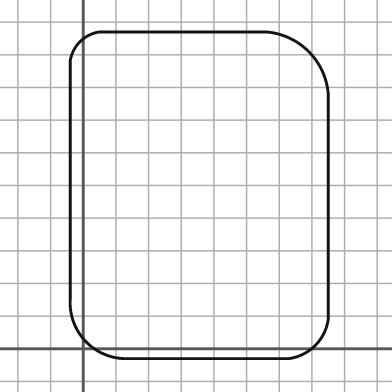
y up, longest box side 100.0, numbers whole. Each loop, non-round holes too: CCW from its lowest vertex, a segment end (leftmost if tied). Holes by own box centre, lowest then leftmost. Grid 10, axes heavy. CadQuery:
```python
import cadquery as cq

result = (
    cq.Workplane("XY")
    .moveTo(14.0, -3.0)
    .lineTo(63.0, -3.0)
    .threePointArc((71.0, 1.0), (75.0, 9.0))
    .lineTo(75.0, 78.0)
    .threePointArc((69.0, 91.0), (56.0, 97.0))
    .lineTo(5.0, 97.0)
    .threePointArc((-1.0, 94.0), (-4.0, 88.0))
    .lineTo(-4.0, 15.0)
    .threePointArc((1.0, 2.0), (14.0, -3.0))
    .close()
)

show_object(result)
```